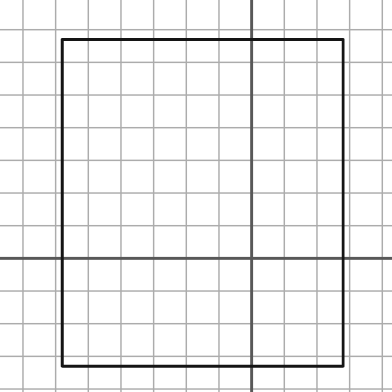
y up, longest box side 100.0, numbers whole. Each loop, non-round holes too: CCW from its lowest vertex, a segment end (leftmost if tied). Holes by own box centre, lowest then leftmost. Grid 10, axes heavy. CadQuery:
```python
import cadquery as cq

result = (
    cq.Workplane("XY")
    .moveTo(-58.0, -33.0)
    .lineTo(28.0, -33.0)
    .lineTo(28.0, 67.0)
    .lineTo(-58.0, 67.0)
    .close()
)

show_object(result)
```